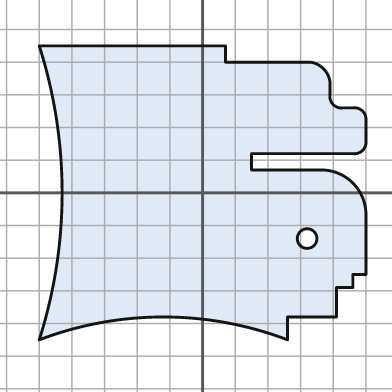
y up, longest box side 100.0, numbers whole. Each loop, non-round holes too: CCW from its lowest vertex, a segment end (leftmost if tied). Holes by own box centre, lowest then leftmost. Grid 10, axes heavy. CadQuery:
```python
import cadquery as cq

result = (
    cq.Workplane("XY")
    .moveTo(-50.0, -45.0)
    .threePointArc((-12.0, -38.0), (26.0, -45.0))
    .lineTo(26.0, -38.0)
    .lineTo(41.0, -38.0)
    .lineTo(41.0, -29.0)
    .lineTo(46.0, -29.0)
    .lineTo(46.0, -25.0)
    .lineTo(50.0, -25.0)
    .lineTo(50.0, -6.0)
    .threePointArc((46.0, 3.0), (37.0, 7.0))
    .lineTo(15.0, 7.0)
    .lineTo(15.0, 12.0)
    .lineTo(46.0, 12.0)
    .threePointArc((49.0, 13.0), (50.0, 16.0))
    .lineTo(50.0, 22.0)
    .threePointArc((49.0, 25.0), (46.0, 26.0))
    .lineTo(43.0, 26.0)
    .threePointArc((40.0, 27.0), (39.0, 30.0))
    .lineTo(39.0, 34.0)
    .threePointArc((37.0, 38.0), (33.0, 40.0))
    .lineTo(7.0, 40.0)
    .lineTo(7.0, 45.0)
    .lineTo(-50.0, 45.0)
    .threePointArc((-43.0, 0.0), (-50.0, -45.0))
    .close()
    .moveTo(32.0, -14.0)
    .circle(3.0)
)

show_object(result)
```